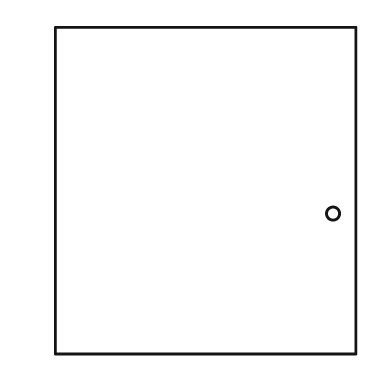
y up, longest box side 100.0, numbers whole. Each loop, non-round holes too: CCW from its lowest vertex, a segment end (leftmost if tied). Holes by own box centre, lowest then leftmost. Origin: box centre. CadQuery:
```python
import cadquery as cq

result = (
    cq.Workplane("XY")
    .moveTo(-46.0, -50.0)
    .lineTo(46.0, -50.0)
    .lineTo(46.0, 50.0)
    .lineTo(-46.0, 50.0)
    .close()
    .moveTo(39.0, -7.0)
    .circle(2.0)
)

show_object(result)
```